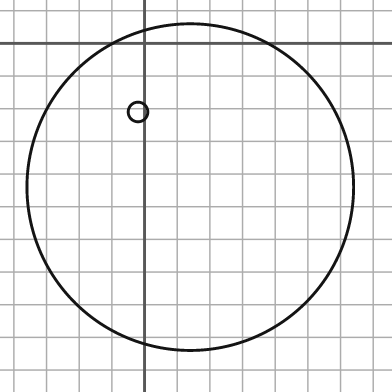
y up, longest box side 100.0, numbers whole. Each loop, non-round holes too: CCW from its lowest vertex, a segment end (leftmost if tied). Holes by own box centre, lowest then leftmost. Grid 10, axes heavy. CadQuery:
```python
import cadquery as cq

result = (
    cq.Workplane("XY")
    .moveTo(14.0, -44.0)
    .circle(50.0)
    .moveTo(-2.0, -21.0)
    .circle(3.0)
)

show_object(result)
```